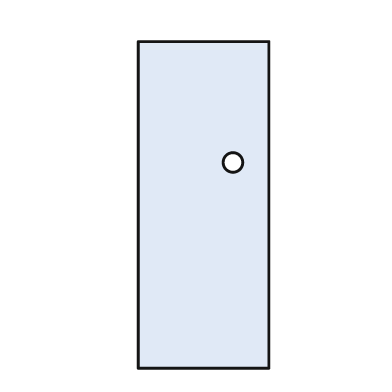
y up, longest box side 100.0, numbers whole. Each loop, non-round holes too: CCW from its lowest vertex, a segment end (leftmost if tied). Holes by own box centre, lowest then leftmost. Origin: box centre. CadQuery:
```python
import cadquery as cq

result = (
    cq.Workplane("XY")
    .moveTo(-20.0, -50.0)
    .lineTo(20.0, -50.0)
    .lineTo(20.0, 50.0)
    .lineTo(-20.0, 50.0)
    .close()
    .moveTo(9.0, 13.0)
    .circle(3.0)
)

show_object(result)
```